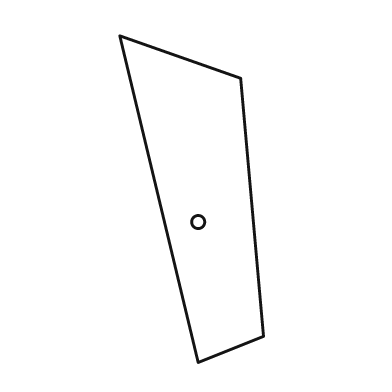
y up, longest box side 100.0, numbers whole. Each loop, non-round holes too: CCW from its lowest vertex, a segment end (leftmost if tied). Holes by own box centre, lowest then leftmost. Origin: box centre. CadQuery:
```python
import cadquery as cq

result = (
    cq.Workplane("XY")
    .moveTo(2.0, -50.0)
    .lineTo(22.0, -42.0)
    .lineTo(15.0, 37.0)
    .lineTo(-22.0, 50.0)
    .close()
    .moveTo(2.0, -7.0)
    .circle(2.0)
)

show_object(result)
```